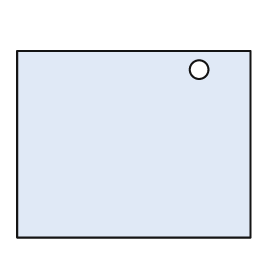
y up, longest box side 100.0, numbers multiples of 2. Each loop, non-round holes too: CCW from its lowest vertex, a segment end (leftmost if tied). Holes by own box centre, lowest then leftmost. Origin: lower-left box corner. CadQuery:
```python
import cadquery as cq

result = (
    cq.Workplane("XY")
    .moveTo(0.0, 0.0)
    .lineTo(100.0, 0.0)
    .lineTo(100.0, 80.0)
    .lineTo(0.0, 80.0)
    .close()
    .moveTo(78.0, 72.0)
    .circle(4.0)
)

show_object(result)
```